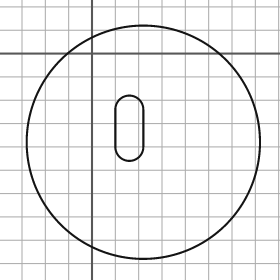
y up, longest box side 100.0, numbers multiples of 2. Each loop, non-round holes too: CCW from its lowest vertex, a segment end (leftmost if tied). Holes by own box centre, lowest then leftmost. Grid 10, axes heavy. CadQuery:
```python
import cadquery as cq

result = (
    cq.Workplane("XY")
    .moveTo(22.0, -38.0)
    .circle(50.0)
    .moveTo(10.0, -40.0)
    .threePointArc((16.0, -46.0), (22.0, -40.0))
    .lineTo(22.0, -24.0)
    .threePointArc((16.0, -18.0), (10.0, -24.0))
    .close()
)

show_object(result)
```